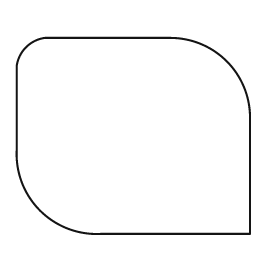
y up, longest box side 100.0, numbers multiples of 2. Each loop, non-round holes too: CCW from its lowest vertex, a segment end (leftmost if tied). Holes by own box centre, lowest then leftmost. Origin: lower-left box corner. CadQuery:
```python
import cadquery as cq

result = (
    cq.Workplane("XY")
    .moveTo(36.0, 0.0)
    .lineTo(100.0, 0.0)
    .lineTo(100.0, 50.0)
    .threePointArc((90.0, 74.0), (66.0, 84.0))
    .lineTo(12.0, 84.0)
    .threePointArc((4.0, 80.0), (0.0, 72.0))
    .lineTo(0.0, 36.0)
    .threePointArc((10.0, 10.0), (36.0, 0.0))
    .close()
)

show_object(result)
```